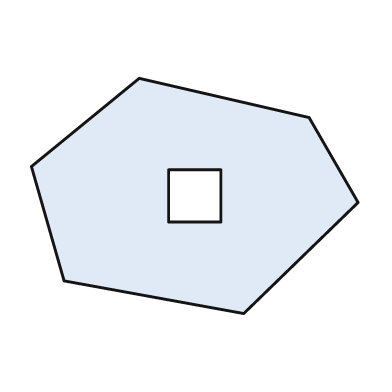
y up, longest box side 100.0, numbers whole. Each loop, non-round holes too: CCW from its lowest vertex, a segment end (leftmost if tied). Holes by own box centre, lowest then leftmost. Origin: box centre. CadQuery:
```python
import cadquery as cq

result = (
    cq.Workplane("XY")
    .moveTo(15.0, -36.0)
    .lineTo(50.0, -2.0)
    .lineTo(35.0, 24.0)
    .lineTo(-17.0, 36.0)
    .lineTo(-50.0, 9.0)
    .lineTo(-40.0, -26.0)
    .close()
    .moveTo(-8.0, -8.0)
    .lineTo(8.0, -8.0)
    .lineTo(8.0, 8.0)
    .lineTo(-8.0, 8.0)
    .close()
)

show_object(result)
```